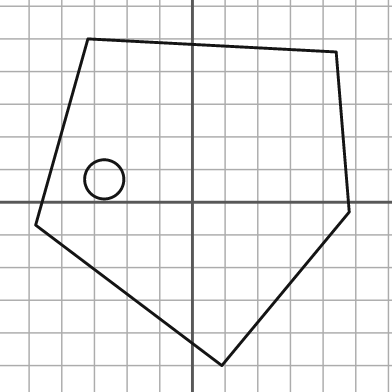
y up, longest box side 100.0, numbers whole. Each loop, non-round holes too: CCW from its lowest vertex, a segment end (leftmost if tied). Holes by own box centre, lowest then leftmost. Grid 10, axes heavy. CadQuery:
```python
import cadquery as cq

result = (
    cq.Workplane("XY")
    .moveTo(9.0, -50.0)
    .lineTo(48.0, -3.0)
    .lineTo(44.0, 46.0)
    .lineTo(-32.0, 50.0)
    .lineTo(-48.0, -7.0)
    .close()
    .moveTo(-27.0, 7.0)
    .circle(6.0)
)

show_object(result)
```